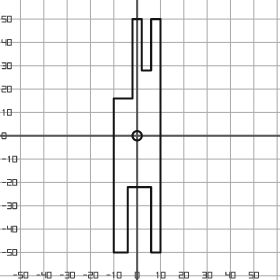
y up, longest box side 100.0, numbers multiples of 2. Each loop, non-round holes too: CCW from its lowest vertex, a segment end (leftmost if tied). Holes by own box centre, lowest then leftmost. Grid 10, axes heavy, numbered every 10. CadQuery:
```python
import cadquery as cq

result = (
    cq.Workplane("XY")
    .moveTo(-10.0, -50.0)
    .lineTo(-4.0, -50.0)
    .lineTo(-4.0, -22.0)
    .lineTo(6.0, -22.0)
    .lineTo(6.0, -50.0)
    .lineTo(10.0, -50.0)
    .lineTo(10.0, 50.0)
    .lineTo(6.0, 50.0)
    .lineTo(6.0, 28.0)
    .lineTo(2.0, 28.0)
    .lineTo(2.0, 50.0)
    .lineTo(-2.0, 50.0)
    .lineTo(-2.0, 16.0)
    .lineTo(-10.0, 16.0)
    .close()
    .moveTo(0.0, 0.0)
    .circle(2.0)
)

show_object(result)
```